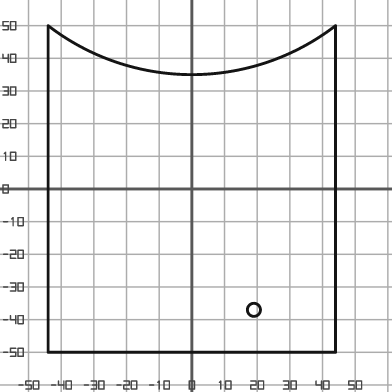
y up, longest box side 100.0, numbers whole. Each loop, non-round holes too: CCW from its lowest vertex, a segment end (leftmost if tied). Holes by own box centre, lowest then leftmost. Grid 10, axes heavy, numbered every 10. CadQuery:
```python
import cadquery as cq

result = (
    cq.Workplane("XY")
    .moveTo(-44.0, -50.0)
    .lineTo(44.0, -50.0)
    .lineTo(44.0, 50.0)
    .threePointArc((0.0, 35.0), (-44.0, 50.0))
    .close()
    .moveTo(19.0, -37.0)
    .circle(2.0)
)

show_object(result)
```